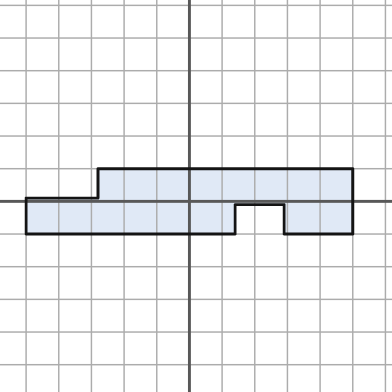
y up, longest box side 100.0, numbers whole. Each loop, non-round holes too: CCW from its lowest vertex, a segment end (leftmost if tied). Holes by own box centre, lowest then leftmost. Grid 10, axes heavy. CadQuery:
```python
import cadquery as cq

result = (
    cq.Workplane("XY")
    .moveTo(-50.0, -10.0)
    .lineTo(14.0, -10.0)
    .lineTo(14.0, -1.0)
    .lineTo(29.0, -1.0)
    .lineTo(29.0, -10.0)
    .lineTo(50.0, -10.0)
    .lineTo(50.0, 10.0)
    .lineTo(-28.0, 10.0)
    .lineTo(-28.0, 1.0)
    .lineTo(-50.0, 1.0)
    .close()
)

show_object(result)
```